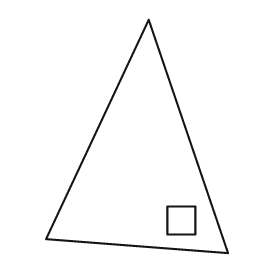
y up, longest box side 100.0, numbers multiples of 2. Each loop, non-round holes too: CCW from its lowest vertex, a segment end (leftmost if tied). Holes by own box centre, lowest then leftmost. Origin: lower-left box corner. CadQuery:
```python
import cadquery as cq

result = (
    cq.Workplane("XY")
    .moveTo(78.0, 0.0)
    .lineTo(44.0, 100.0)
    .lineTo(0.0, 6.0)
    .close()
    .moveTo(52.0, 8.0)
    .lineTo(64.0, 8.0)
    .lineTo(64.0, 20.0)
    .lineTo(52.0, 20.0)
    .close()
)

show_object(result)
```